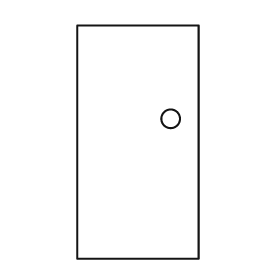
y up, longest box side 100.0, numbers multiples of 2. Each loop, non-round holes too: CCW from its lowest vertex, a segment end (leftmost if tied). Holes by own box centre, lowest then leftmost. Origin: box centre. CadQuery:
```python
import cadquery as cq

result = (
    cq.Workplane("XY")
    .moveTo(-26.0, -50.0)
    .lineTo(26.0, -50.0)
    .lineTo(26.0, 50.0)
    .lineTo(-26.0, 50.0)
    .close()
    .moveTo(14.0, 10.0)
    .circle(4.0)
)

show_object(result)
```